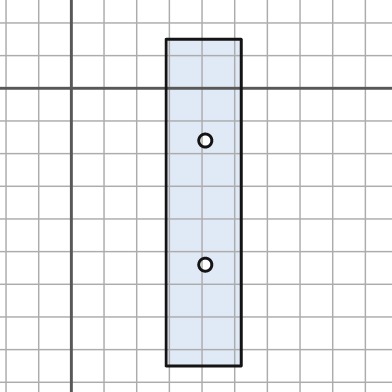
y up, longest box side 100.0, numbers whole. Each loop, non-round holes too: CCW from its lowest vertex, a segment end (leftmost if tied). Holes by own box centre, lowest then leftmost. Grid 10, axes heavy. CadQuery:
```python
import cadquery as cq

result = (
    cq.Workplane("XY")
    .moveTo(29.0, -85.0)
    .lineTo(52.0, -85.0)
    .lineTo(52.0, 15.0)
    .lineTo(29.0, 15.0)
    .close()
    .moveTo(41.0, -54.0)
    .circle(2.0)
    .moveTo(41.0, -16.0)
    .circle(2.0)
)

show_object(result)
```